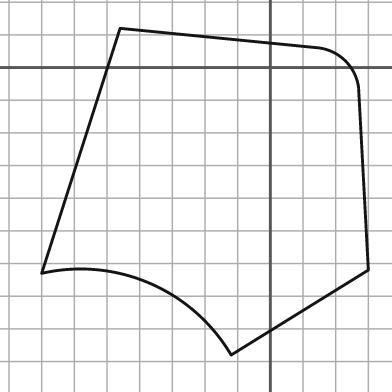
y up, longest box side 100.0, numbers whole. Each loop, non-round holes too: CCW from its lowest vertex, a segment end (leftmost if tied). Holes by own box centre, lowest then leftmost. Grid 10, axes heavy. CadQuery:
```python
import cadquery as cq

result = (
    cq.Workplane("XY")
    .moveTo(-12.0, -88.0)
    .lineTo(30.0, -62.0)
    .lineTo(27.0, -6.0)
    .threePointArc((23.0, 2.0), (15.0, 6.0))
    .lineTo(-46.0, 12.0)
    .lineTo(-70.0, -63.0)
    .threePointArc((-37.0, -66.0), (-12.0, -88.0))
    .close()
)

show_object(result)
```